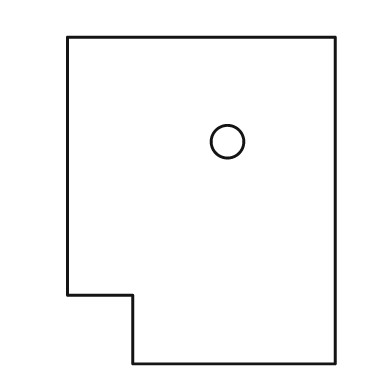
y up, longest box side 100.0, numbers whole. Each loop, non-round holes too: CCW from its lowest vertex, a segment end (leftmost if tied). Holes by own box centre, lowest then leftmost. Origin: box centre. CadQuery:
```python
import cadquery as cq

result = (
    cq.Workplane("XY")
    .moveTo(-21.0, -50.0)
    .lineTo(41.0, -50.0)
    .lineTo(41.0, 50.0)
    .lineTo(-41.0, 50.0)
    .lineTo(-41.0, -29.0)
    .lineTo(-21.0, -29.0)
    .close()
    .moveTo(8.0, 18.0)
    .circle(5.0)
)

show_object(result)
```